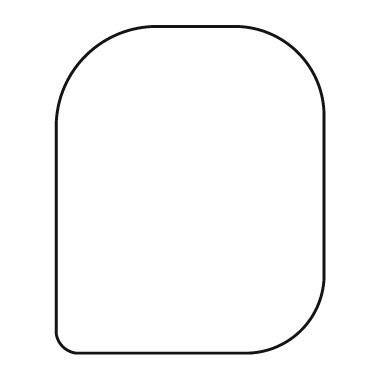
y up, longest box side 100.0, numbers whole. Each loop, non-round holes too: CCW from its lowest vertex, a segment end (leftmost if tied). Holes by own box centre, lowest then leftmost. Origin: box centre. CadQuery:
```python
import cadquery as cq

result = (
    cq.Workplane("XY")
    .moveTo(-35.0, -50.0)
    .lineTo(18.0, -50.0)
    .threePointArc((34.0, -43.0), (41.0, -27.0))
    .lineTo(41.0, 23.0)
    .threePointArc((33.0, 42.0), (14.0, 50.0))
    .lineTo(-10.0, 50.0)
    .threePointArc((-32.0, 41.0), (-41.0, 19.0))
    .lineTo(-41.0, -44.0)
    .threePointArc((-39.0, -48.0), (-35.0, -50.0))
    .close()
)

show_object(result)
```